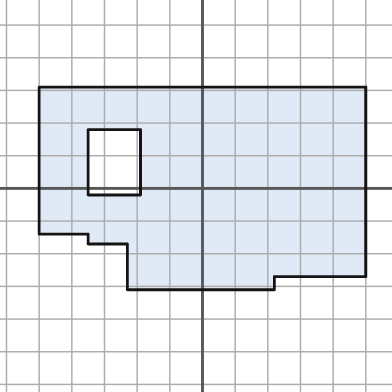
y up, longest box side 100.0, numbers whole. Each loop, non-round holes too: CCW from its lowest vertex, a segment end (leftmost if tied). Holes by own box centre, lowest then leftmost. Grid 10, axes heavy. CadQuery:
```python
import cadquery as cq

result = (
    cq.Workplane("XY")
    .moveTo(-23.0, -31.0)
    .lineTo(22.0, -31.0)
    .lineTo(22.0, -27.0)
    .lineTo(50.0, -27.0)
    .lineTo(50.0, 31.0)
    .lineTo(-50.0, 31.0)
    .lineTo(-50.0, -14.0)
    .lineTo(-35.0, -14.0)
    .lineTo(-35.0, -17.0)
    .lineTo(-23.0, -17.0)
    .close()
    .moveTo(-35.0, -2.0)
    .lineTo(-19.0, -2.0)
    .lineTo(-19.0, 18.0)
    .lineTo(-35.0, 18.0)
    .close()
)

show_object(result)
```